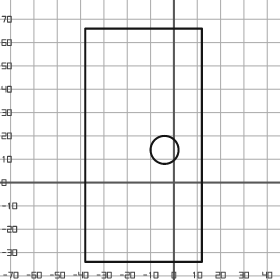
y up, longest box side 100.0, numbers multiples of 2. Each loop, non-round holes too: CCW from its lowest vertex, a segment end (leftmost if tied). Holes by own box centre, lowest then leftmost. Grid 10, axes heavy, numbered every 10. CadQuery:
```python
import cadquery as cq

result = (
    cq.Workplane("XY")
    .moveTo(-38.0, -34.0)
    .lineTo(12.0, -34.0)
    .lineTo(12.0, 66.0)
    .lineTo(-38.0, 66.0)
    .close()
    .moveTo(-4.0, 14.0)
    .circle(6.0)
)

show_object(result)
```